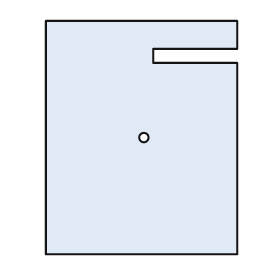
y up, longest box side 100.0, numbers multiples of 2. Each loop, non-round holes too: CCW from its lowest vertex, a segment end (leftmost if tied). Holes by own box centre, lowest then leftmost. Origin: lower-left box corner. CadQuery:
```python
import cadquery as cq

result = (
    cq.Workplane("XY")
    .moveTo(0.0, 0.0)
    .lineTo(82.0, 0.0)
    .lineTo(82.0, 82.0)
    .lineTo(46.0, 82.0)
    .lineTo(46.0, 88.0)
    .lineTo(82.0, 88.0)
    .lineTo(82.0, 100.0)
    .lineTo(0.0, 100.0)
    .close()
    .moveTo(42.0, 50.0)
    .circle(2.0)
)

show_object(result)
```